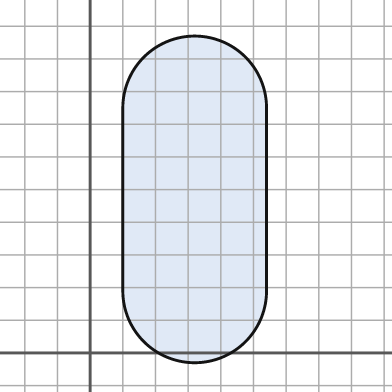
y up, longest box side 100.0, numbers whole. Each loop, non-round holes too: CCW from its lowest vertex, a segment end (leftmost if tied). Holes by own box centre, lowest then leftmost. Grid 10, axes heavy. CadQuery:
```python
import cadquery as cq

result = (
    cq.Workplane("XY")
    .moveTo(10.0, 19.0)
    .threePointArc((32.0, -3.0), (54.0, 19.0))
    .lineTo(54.0, 75.0)
    .threePointArc((32.0, 97.0), (10.0, 75.0))
    .close()
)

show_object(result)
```